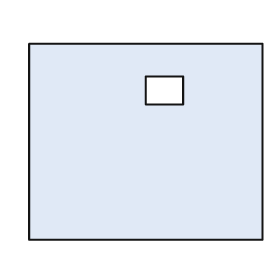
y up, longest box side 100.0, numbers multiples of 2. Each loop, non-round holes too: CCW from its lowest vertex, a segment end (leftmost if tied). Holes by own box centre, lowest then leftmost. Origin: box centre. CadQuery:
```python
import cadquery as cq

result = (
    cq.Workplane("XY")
    .moveTo(-50.0, -42.0)
    .lineTo(50.0, -42.0)
    .lineTo(50.0, 42.0)
    .lineTo(-50.0, 42.0)
    .close()
    .moveTo(0.0, 16.0)
    .lineTo(16.0, 16.0)
    .lineTo(16.0, 28.0)
    .lineTo(0.0, 28.0)
    .close()
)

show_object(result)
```